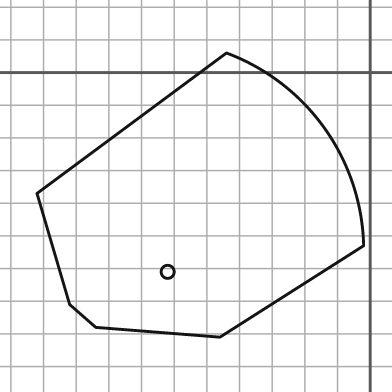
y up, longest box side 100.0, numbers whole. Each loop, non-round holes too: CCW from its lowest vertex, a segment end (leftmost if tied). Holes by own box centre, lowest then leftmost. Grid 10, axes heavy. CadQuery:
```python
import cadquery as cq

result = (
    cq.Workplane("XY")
    .moveTo(-46.0, -81.0)
    .lineTo(-2.0, -53.0)
    .threePointArc((-14.0, -17.0), (-44.0, 6.0))
    .lineTo(-102.0, -37.0)
    .lineTo(-92.0, -71.0)
    .lineTo(-84.0, -78.0)
    .close()
    .moveTo(-62.0, -61.0)
    .circle(2.0)
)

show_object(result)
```